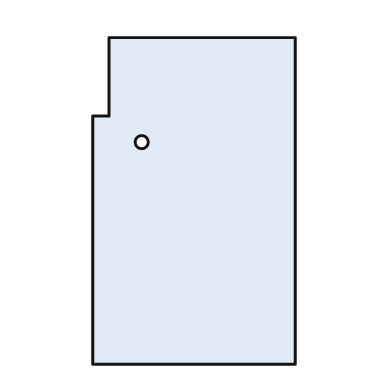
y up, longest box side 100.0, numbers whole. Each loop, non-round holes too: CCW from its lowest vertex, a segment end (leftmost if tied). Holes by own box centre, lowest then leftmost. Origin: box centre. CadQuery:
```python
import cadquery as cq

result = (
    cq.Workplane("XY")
    .moveTo(-31.0, -50.0)
    .lineTo(31.0, -50.0)
    .lineTo(31.0, 50.0)
    .lineTo(-26.0, 50.0)
    .lineTo(-26.0, 26.0)
    .lineTo(-31.0, 26.0)
    .close()
    .moveTo(-16.0, 18.0)
    .circle(2.0)
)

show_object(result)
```